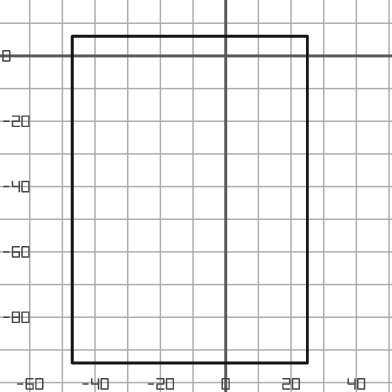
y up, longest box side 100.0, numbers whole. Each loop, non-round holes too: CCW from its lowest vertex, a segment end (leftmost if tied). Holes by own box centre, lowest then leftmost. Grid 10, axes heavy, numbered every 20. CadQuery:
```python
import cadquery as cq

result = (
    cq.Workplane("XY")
    .moveTo(-47.0, -94.0)
    .lineTo(25.0, -94.0)
    .lineTo(25.0, 6.0)
    .lineTo(-47.0, 6.0)
    .close()
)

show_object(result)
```